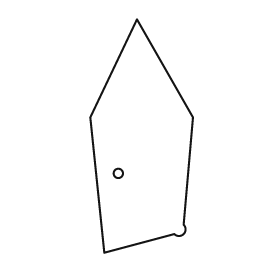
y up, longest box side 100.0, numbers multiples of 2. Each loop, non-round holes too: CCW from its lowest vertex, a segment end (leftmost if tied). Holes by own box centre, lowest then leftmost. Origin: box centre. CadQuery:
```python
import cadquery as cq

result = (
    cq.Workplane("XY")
    .moveTo(-16.0, -50.0)
    .lineTo(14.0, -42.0)
    .threePointArc((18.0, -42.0), (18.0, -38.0))
    .lineTo(22.0, 8.0)
    .lineTo(-2.0, 50.0)
    .lineTo(-22.0, 8.0)
    .close()
    .moveTo(-10.0, -16.0)
    .circle(2.0)
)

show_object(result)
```